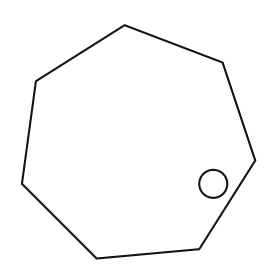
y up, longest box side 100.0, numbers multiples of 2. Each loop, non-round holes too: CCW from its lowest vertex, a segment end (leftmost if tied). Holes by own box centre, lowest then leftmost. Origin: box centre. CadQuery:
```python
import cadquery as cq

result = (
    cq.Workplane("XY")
    .moveTo(-18.0, -50.0)
    .lineTo(26.0, -46.0)
    .lineTo(50.0, -8.0)
    .lineTo(36.0, 34.0)
    .lineTo(-6.0, 50.0)
    .lineTo(-44.0, 26.0)
    .lineTo(-50.0, -18.0)
    .close()
    .moveTo(32.0, -18.0)
    .circle(6.0)
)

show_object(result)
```